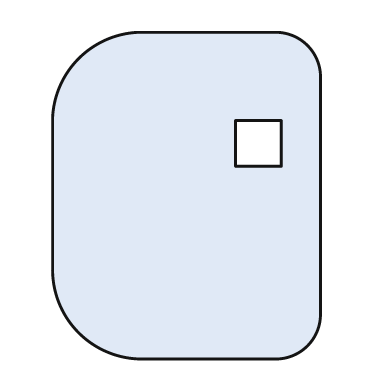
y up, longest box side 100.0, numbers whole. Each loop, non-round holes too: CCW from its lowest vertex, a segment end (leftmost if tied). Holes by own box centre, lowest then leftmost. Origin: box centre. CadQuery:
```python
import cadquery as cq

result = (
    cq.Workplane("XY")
    .moveTo(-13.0, -50.0)
    .lineTo(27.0, -50.0)
    .threePointArc((37.0, -46.0), (41.0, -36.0))
    .lineTo(41.0, 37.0)
    .threePointArc((37.0, 46.0), (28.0, 50.0))
    .lineTo(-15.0, 50.0)
    .threePointArc((-33.0, 42.0), (-41.0, 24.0))
    .lineTo(-41.0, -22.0)
    .threePointArc((-33.0, -42.0), (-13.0, -50.0))
    .close()
    .moveTo(15.0, 9.0)
    .lineTo(29.0, 9.0)
    .lineTo(29.0, 23.0)
    .lineTo(15.0, 23.0)
    .close()
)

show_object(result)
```